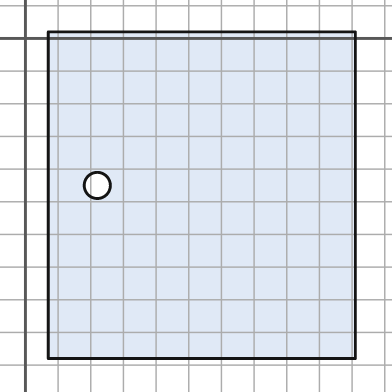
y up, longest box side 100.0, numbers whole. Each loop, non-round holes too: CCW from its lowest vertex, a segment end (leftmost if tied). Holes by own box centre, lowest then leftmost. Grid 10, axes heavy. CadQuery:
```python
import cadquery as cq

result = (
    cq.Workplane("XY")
    .moveTo(7.0, -98.0)
    .lineTo(101.0, -98.0)
    .lineTo(101.0, 2.0)
    .lineTo(7.0, 2.0)
    .close()
    .moveTo(22.0, -45.0)
    .circle(4.0)
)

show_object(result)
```